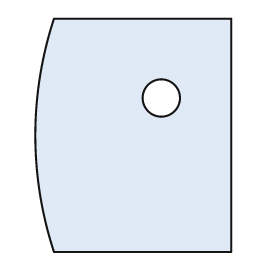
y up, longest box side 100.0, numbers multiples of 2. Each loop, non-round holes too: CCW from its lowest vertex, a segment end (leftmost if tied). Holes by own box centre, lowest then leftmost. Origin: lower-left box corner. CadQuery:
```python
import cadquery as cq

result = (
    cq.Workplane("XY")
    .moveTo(8.0, 0.0)
    .lineTo(84.0, 0.0)
    .lineTo(84.0, 100.0)
    .lineTo(8.0, 100.0)
    .threePointArc((0.0, 50.0), (8.0, 0.0))
    .close()
    .moveTo(54.0, 66.0)
    .circle(8.0)
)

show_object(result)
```